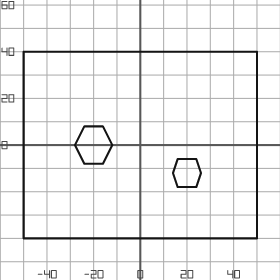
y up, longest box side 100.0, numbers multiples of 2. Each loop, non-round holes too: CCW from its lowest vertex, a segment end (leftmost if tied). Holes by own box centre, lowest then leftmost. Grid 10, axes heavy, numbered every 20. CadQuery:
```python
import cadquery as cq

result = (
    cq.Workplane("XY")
    .moveTo(-50.0, -40.0)
    .lineTo(50.0, -40.0)
    .lineTo(50.0, 40.0)
    .lineTo(-50.0, 40.0)
    .close()
    .moveTo(16.0, -18.0)
    .lineTo(24.0, -18.0)
    .lineTo(26.0, -12.0)
    .lineTo(24.0, -6.0)
    .lineTo(16.0, -6.0)
    .lineTo(14.0, -12.0)
    .close()
    .moveTo(-24.0, -8.0)
    .lineTo(-16.0, -8.0)
    .lineTo(-12.0, 0.0)
    .lineTo(-16.0, 8.0)
    .lineTo(-24.0, 8.0)
    .lineTo(-28.0, 0.0)
    .close()
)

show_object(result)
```